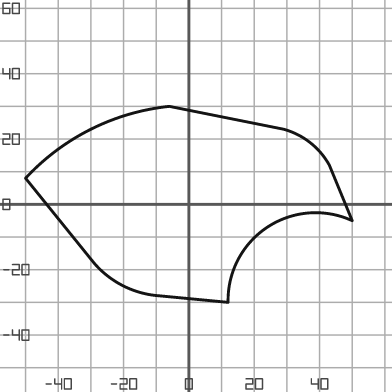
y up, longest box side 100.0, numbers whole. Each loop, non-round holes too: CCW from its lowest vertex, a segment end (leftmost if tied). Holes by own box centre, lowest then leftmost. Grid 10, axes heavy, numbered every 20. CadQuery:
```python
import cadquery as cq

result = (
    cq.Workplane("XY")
    .moveTo(12.0, -30.0)
    .threePointArc((24.0, -7.0), (50.0, -5.0))
    .lineTo(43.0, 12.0)
    .threePointArc((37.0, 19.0), (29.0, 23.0))
    .lineTo(-6.0, 30.0)
    .threePointArc((-30.0, 23.0), (-50.0, 8.0))
    .lineTo(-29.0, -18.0)
    .threePointArc((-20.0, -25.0), (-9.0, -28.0))
    .close()
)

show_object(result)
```